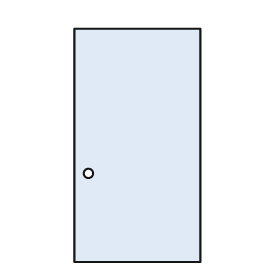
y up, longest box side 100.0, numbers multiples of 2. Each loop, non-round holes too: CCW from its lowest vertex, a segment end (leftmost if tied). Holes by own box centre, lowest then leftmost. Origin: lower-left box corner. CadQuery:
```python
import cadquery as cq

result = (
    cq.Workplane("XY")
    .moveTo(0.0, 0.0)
    .lineTo(54.0, 0.0)
    .lineTo(54.0, 100.0)
    .lineTo(0.0, 100.0)
    .close()
    .moveTo(6.0, 38.0)
    .circle(2.0)
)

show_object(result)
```